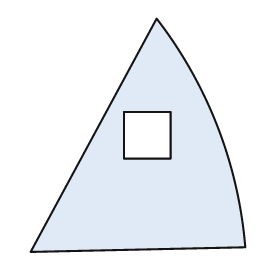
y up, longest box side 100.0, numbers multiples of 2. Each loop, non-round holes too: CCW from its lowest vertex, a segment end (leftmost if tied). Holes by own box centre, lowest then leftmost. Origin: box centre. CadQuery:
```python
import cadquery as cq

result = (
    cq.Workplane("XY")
    .moveTo(-46.0, -50.0)
    .lineTo(46.0, -48.0)
    .threePointArc((34.0, 4.0), (8.0, 50.0))
    .close()
    .moveTo(-6.0, -10.0)
    .lineTo(14.0, -10.0)
    .lineTo(14.0, 10.0)
    .lineTo(-6.0, 10.0)
    .close()
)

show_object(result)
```